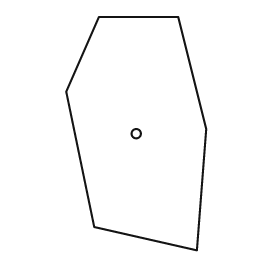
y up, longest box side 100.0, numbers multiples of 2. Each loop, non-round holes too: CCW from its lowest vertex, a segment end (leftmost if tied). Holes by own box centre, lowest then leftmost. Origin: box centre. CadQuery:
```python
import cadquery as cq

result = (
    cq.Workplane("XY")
    .moveTo(26.0, -50.0)
    .lineTo(30.0, 2.0)
    .lineTo(18.0, 50.0)
    .lineTo(-16.0, 50.0)
    .lineTo(-30.0, 18.0)
    .lineTo(-18.0, -40.0)
    .close()
    .moveTo(0.0, 0.0)
    .circle(2.0)
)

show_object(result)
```